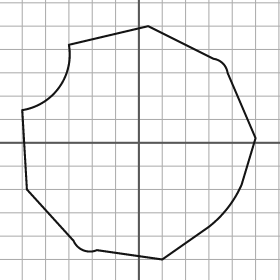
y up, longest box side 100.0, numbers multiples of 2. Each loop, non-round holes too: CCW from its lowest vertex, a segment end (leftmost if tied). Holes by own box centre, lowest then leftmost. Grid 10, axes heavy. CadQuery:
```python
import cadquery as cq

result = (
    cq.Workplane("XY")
    .moveTo(10.0, -50.0)
    .lineTo(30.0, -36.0)
    .threePointArc((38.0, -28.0), (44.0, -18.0))
    .lineTo(50.0, 2.0)
    .lineTo(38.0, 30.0)
    .threePointArc((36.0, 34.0), (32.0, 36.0))
    .lineTo(4.0, 50.0)
    .lineTo(-30.0, 42.0)
    .threePointArc((-34.0, 24.0), (-50.0, 14.0))
    .lineTo(-48.0, -20.0)
    .lineTo(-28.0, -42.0)
    .threePointArc((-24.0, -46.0), (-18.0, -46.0))
    .close()
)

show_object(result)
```